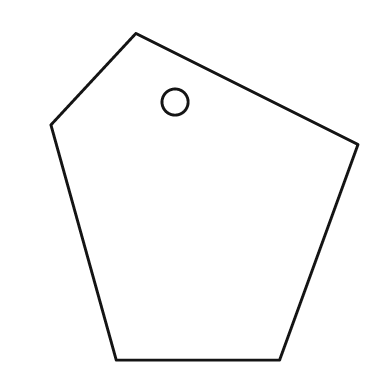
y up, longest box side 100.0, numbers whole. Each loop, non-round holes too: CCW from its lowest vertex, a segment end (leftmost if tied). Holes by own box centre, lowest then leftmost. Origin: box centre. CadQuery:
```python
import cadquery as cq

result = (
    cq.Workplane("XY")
    .moveTo(-27.0, -50.0)
    .lineTo(23.0, -50.0)
    .lineTo(47.0, 16.0)
    .lineTo(-21.0, 50.0)
    .lineTo(-47.0, 22.0)
    .close()
    .moveTo(-9.0, 29.0)
    .circle(4.0)
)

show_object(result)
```